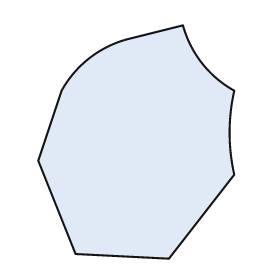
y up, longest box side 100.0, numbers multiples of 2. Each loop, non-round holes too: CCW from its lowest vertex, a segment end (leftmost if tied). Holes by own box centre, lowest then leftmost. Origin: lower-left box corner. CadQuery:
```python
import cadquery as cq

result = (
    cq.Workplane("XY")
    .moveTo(56.0, 0.0)
    .lineTo(84.0, 36.0)
    .threePointArc((82.0, 54.0), (84.0, 72.0))
    .threePointArc((70.0, 84.0), (62.0, 100.0))
    .lineTo(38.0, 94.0)
    .threePointArc((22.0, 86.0), (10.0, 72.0))
    .lineTo(0.0, 42.0)
    .lineTo(16.0, 2.0)
    .close()
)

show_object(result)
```